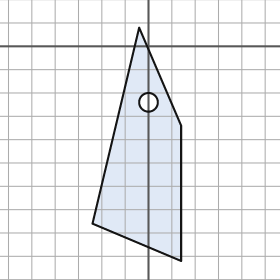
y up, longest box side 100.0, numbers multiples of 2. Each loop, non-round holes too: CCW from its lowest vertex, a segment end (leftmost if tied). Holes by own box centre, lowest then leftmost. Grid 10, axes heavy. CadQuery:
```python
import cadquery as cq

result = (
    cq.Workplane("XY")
    .moveTo(14.0, -92.0)
    .lineTo(14.0, -34.0)
    .lineTo(-4.0, 8.0)
    .lineTo(-24.0, -76.0)
    .close()
    .moveTo(0.0, -24.0)
    .circle(4.0)
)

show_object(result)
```